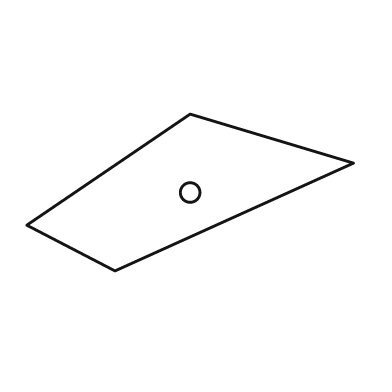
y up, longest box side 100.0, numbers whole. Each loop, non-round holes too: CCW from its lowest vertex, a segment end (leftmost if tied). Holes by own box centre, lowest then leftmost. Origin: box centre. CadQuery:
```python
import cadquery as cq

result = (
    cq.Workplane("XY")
    .moveTo(-23.0, -24.0)
    .lineTo(50.0, 9.0)
    .lineTo(0.0, 24.0)
    .lineTo(-50.0, -10.0)
    .close()
    .moveTo(0.0, 0.0)
    .circle(3.0)
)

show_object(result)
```